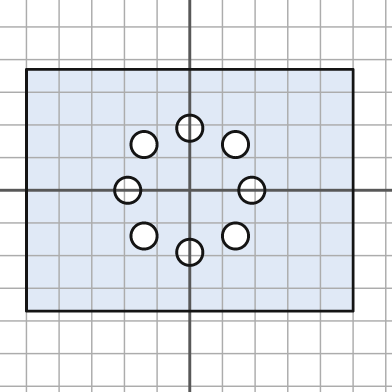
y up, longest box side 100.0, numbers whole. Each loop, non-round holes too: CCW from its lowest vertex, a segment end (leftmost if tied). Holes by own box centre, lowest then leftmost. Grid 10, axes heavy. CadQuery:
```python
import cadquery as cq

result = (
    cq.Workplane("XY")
    .moveTo(-50.0, -37.0)
    .lineTo(50.0, -37.0)
    .lineTo(50.0, 37.0)
    .lineTo(-50.0, 37.0)
    .close()
    .moveTo(0.0, -19.0)
    .circle(4.0)
    .moveTo(-14.0, -14.0)
    .circle(4.0)
    .moveTo(14.0, -14.0)
    .circle(4.0)
    .moveTo(-19.0, 0.0)
    .circle(4.0)
    .moveTo(19.0, 0.0)
    .circle(4.0)
    .moveTo(-14.0, 14.0)
    .circle(4.0)
    .moveTo(14.0, 14.0)
    .circle(4.0)
    .moveTo(0.0, 19.0)
    .circle(4.0)
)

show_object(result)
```